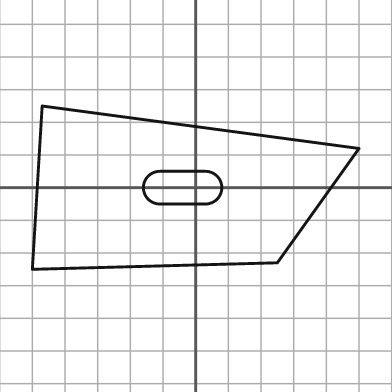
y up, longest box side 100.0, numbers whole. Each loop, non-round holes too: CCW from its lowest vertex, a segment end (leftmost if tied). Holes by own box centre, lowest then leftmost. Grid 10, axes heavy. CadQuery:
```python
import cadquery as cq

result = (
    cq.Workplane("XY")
    .moveTo(-50.0, -25.0)
    .lineTo(25.0, -23.0)
    .lineTo(50.0, 12.0)
    .lineTo(-47.0, 25.0)
    .close()
    .moveTo(-11.0, -5.0)
    .lineTo(3.0, -5.0)
    .threePointArc((8.0, 0.0), (3.0, 5.0))
    .lineTo(-11.0, 5.0)
    .threePointArc((-16.0, 0.0), (-11.0, -5.0))
    .close()
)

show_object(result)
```